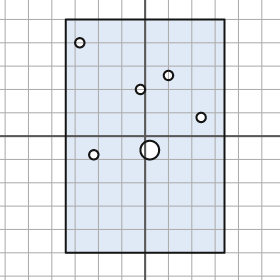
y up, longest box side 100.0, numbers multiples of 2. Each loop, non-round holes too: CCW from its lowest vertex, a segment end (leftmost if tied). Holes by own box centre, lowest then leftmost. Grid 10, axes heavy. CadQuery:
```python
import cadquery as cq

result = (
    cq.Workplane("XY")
    .moveTo(-34.0, -50.0)
    .lineTo(34.0, -50.0)
    .lineTo(34.0, 50.0)
    .lineTo(-34.0, 50.0)
    .close()
    .moveTo(-22.0, -8.0)
    .circle(2.0)
    .moveTo(2.0, -6.0)
    .circle(4.0)
    .moveTo(24.0, 8.0)
    .circle(2.0)
    .moveTo(-2.0, 20.0)
    .circle(2.0)
    .moveTo(10.0, 26.0)
    .circle(2.0)
    .moveTo(-28.0, 40.0)
    .circle(2.0)
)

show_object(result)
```